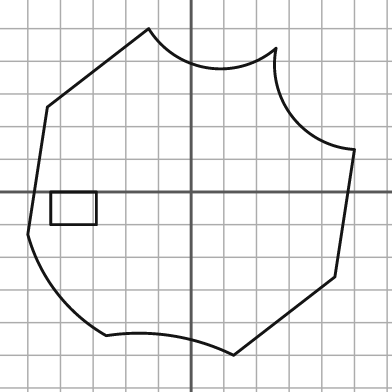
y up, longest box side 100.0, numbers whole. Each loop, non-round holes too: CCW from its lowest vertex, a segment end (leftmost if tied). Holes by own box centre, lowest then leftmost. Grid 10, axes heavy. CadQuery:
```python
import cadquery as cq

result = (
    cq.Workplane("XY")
    .moveTo(13.0, -50.0)
    .lineTo(44.0, -26.0)
    .lineTo(50.0, 13.0)
    .threePointArc((31.0, 23.0), (26.0, 44.0))
    .threePointArc((5.0, 38.0), (-13.0, 50.0))
    .lineTo(-44.0, 26.0)
    .lineTo(-50.0, -13.0)
    .threePointArc((-41.0, -31.0), (-26.0, -44.0))
    .threePointArc((-6.0, -44.0), (13.0, -50.0))
    .close()
    .moveTo(-43.0, -10.0)
    .lineTo(-29.0, -10.0)
    .lineTo(-29.0, 0.0)
    .lineTo(-43.0, 0.0)
    .close()
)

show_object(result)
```